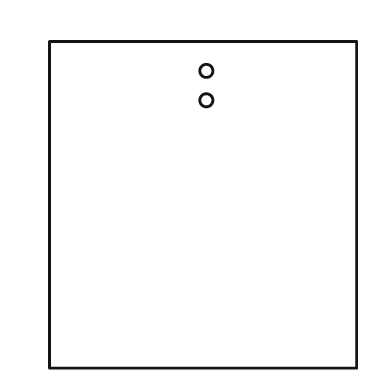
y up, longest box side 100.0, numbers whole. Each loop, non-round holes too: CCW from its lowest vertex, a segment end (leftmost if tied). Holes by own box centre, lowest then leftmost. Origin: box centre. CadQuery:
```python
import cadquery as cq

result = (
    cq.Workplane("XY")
    .moveTo(-47.0, -50.0)
    .lineTo(47.0, -50.0)
    .lineTo(47.0, 50.0)
    .lineTo(-47.0, 50.0)
    .close()
    .moveTo(1.0, 32.0)
    .circle(2.0)
    .moveTo(1.0, 41.0)
    .circle(2.0)
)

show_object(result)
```